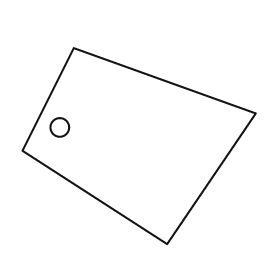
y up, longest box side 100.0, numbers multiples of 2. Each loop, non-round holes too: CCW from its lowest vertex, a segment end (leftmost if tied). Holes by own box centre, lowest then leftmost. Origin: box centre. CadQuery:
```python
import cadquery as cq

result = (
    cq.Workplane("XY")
    .moveTo(12.0, -42.0)
    .lineTo(50.0, 14.0)
    .lineTo(-28.0, 42.0)
    .lineTo(-50.0, -2.0)
    .close()
    .moveTo(-34.0, 8.0)
    .circle(4.0)
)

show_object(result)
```